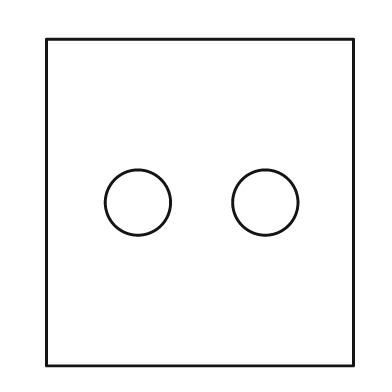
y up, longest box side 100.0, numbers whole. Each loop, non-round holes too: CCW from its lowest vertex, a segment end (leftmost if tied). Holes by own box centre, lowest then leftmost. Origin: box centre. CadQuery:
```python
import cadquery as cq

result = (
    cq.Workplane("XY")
    .moveTo(-47.0, -50.0)
    .lineTo(47.0, -50.0)
    .lineTo(47.0, 50.0)
    .lineTo(-47.0, 50.0)
    .close()
    .moveTo(-19.0, 0.0)
    .circle(10.0)
    .moveTo(20.0, 0.0)
    .circle(10.0)
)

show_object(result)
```